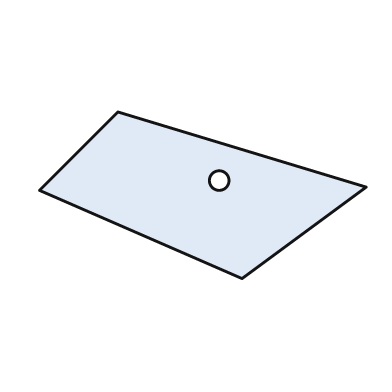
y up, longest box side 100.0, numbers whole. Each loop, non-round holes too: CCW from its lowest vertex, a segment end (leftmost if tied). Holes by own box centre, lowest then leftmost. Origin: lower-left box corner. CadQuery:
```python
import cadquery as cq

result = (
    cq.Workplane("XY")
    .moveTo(62.0, 0.0)
    .lineTo(100.0, 28.0)
    .lineTo(24.0, 51.0)
    .lineTo(0.0, 27.0)
    .close()
    .moveTo(55.0, 30.0)
    .circle(3.0)
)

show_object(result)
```